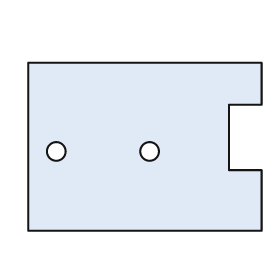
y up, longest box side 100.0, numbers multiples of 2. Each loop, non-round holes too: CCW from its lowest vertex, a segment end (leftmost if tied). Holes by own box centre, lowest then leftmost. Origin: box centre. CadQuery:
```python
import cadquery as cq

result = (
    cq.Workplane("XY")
    .moveTo(-50.0, -36.0)
    .lineTo(50.0, -36.0)
    .lineTo(50.0, -10.0)
    .lineTo(36.0, -10.0)
    .lineTo(36.0, 18.0)
    .lineTo(50.0, 18.0)
    .lineTo(50.0, 36.0)
    .lineTo(-50.0, 36.0)
    .close()
    .moveTo(-38.0, -2.0)
    .circle(4.0)
    .moveTo(2.0, -2.0)
    .circle(4.0)
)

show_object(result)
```